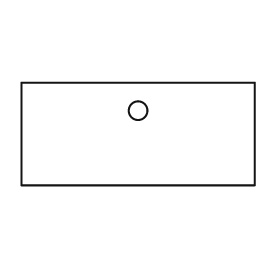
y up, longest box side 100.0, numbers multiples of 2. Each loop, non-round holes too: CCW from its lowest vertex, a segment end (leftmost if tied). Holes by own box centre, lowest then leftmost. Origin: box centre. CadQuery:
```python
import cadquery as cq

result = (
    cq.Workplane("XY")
    .moveTo(-50.0, -22.0)
    .lineTo(50.0, -22.0)
    .lineTo(50.0, 22.0)
    .lineTo(-50.0, 22.0)
    .close()
    .moveTo(0.0, 10.0)
    .circle(4.0)
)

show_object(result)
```